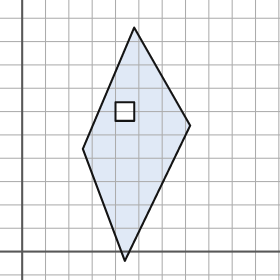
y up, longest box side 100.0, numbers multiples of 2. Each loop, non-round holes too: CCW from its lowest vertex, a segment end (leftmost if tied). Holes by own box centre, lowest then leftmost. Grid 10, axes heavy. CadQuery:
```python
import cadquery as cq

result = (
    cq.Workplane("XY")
    .moveTo(44.0, -4.0)
    .lineTo(72.0, 54.0)
    .lineTo(48.0, 96.0)
    .lineTo(26.0, 44.0)
    .close()
    .moveTo(40.0, 56.0)
    .lineTo(48.0, 56.0)
    .lineTo(48.0, 64.0)
    .lineTo(40.0, 64.0)
    .close()
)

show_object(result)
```